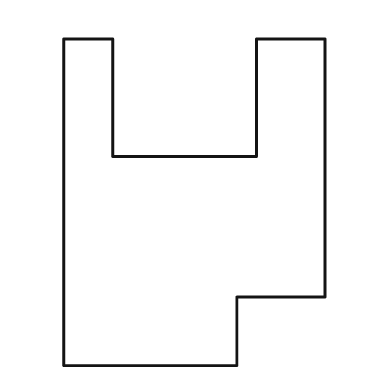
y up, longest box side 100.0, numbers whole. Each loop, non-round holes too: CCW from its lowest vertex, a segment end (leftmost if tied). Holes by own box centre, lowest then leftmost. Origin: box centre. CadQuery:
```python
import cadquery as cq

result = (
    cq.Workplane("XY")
    .moveTo(-40.0, -50.0)
    .lineTo(13.0, -50.0)
    .lineTo(13.0, -29.0)
    .lineTo(40.0, -29.0)
    .lineTo(40.0, 50.0)
    .lineTo(19.0, 50.0)
    .lineTo(19.0, 14.0)
    .lineTo(-25.0, 14.0)
    .lineTo(-25.0, 50.0)
    .lineTo(-40.0, 50.0)
    .close()
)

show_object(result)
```